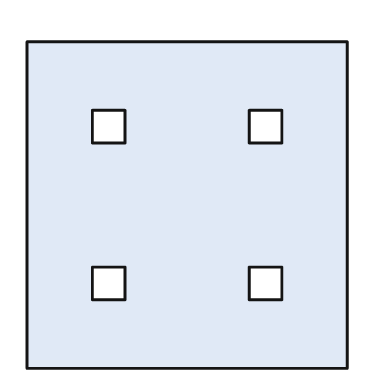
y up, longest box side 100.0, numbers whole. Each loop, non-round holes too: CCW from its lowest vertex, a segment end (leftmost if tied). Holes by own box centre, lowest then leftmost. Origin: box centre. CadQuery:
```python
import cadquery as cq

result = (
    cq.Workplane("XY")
    .moveTo(-49.0, -50.0)
    .lineTo(49.0, -50.0)
    .lineTo(49.0, 50.0)
    .lineTo(-49.0, 50.0)
    .close()
    .moveTo(-29.0, -29.0)
    .lineTo(-19.0, -29.0)
    .lineTo(-19.0, -19.0)
    .lineTo(-29.0, -19.0)
    .close()
    .moveTo(19.0, -29.0)
    .lineTo(29.0, -29.0)
    .lineTo(29.0, -19.0)
    .lineTo(19.0, -19.0)
    .close()
    .moveTo(-29.0, 19.0)
    .lineTo(-19.0, 19.0)
    .lineTo(-19.0, 29.0)
    .lineTo(-29.0, 29.0)
    .close()
    .moveTo(19.0, 19.0)
    .lineTo(29.0, 19.0)
    .lineTo(29.0, 29.0)
    .lineTo(19.0, 29.0)
    .close()
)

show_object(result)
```